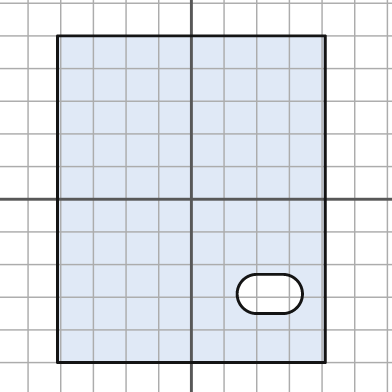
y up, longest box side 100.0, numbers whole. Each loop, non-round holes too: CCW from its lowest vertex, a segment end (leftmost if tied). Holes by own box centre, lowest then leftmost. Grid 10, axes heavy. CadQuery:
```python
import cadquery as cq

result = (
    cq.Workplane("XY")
    .moveTo(-41.0, -50.0)
    .lineTo(41.0, -50.0)
    .lineTo(41.0, 50.0)
    .lineTo(-41.0, 50.0)
    .close()
    .moveTo(20.0, -35.0)
    .lineTo(28.0, -35.0)
    .threePointArc((34.0, -29.0), (28.0, -23.0))
    .lineTo(20.0, -23.0)
    .threePointArc((14.0, -29.0), (20.0, -35.0))
    .close()
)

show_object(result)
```